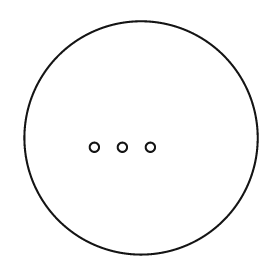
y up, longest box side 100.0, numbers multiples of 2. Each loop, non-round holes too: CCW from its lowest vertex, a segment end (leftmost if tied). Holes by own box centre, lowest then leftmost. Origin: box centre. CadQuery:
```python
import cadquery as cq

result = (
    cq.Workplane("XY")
    .moveTo(0.0, 0.0)
    .circle(50.0)
    .moveTo(-20.0, -4.0)
    .circle(2.0)
    .moveTo(-8.0, -4.0)
    .circle(2.0)
    .moveTo(4.0, -4.0)
    .circle(2.0)
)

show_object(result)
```